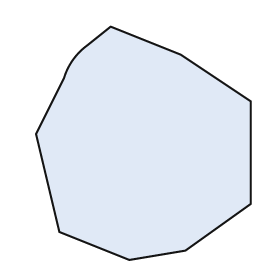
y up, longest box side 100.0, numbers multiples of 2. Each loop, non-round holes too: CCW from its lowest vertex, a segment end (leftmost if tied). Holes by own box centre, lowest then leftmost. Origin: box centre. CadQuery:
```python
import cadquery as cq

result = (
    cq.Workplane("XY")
    .moveTo(-6.0, -50.0)
    .lineTo(18.0, -46.0)
    .lineTo(46.0, -26.0)
    .lineTo(46.0, 18.0)
    .lineTo(16.0, 38.0)
    .lineTo(-14.0, 50.0)
    .lineTo(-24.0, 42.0)
    .threePointArc((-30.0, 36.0), (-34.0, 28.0))
    .lineTo(-46.0, 4.0)
    .lineTo(-36.0, -38.0)
    .close()
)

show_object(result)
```